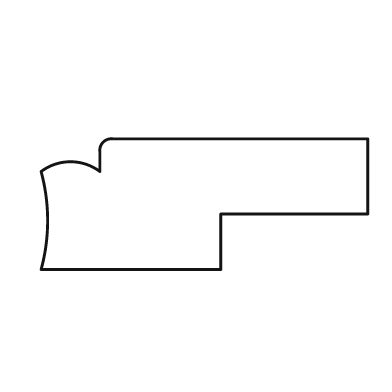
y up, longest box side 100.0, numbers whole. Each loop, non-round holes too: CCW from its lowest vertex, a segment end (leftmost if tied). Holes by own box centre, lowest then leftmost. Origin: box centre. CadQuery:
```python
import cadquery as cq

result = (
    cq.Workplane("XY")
    .moveTo(-50.0, -20.0)
    .lineTo(5.0, -20.0)
    .lineTo(5.0, -3.0)
    .lineTo(50.0, -3.0)
    .lineTo(50.0, 20.0)
    .lineTo(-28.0, 20.0)
    .threePointArc((-31.0, 19.0), (-32.0, 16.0))
    .lineTo(-32.0, 10.0)
    .threePointArc((-41.0, 13.0), (-50.0, 10.0))
    .threePointArc((-48.0, -5.0), (-50.0, -20.0))
    .close()
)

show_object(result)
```